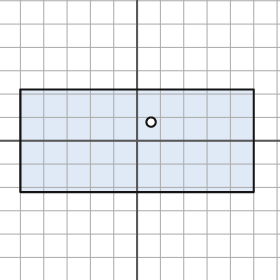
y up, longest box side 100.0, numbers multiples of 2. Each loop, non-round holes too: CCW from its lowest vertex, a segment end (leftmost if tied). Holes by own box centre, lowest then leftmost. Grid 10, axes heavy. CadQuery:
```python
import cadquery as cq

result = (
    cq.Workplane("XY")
    .moveTo(-50.0, -22.0)
    .lineTo(50.0, -22.0)
    .lineTo(50.0, 22.0)
    .lineTo(-50.0, 22.0)
    .close()
    .moveTo(6.0, 8.0)
    .circle(2.0)
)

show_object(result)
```